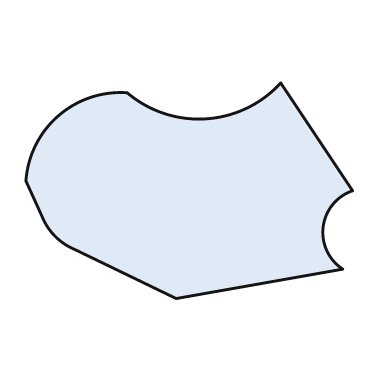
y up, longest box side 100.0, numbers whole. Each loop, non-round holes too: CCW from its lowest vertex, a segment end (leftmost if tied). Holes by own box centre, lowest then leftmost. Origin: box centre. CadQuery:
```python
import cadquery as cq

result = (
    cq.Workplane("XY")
    .moveTo(-4.0, -33.0)
    .lineTo(47.0, -24.0)
    .threePointArc((41.0, -11.0), (50.0, 0.0))
    .lineTo(28.0, 33.0)
    .threePointArc((5.0, 22.0), (-19.0, 30.0))
    .threePointArc((-40.0, 23.0), (-50.0, 3.0))
    .lineTo(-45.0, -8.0)
    .threePointArc((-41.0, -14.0), (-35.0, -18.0))
    .close()
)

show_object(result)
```